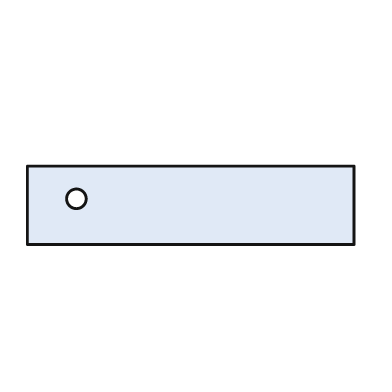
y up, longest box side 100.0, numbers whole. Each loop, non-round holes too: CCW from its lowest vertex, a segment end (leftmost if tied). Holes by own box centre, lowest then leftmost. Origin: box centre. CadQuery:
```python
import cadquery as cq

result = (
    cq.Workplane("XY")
    .moveTo(-50.0, -12.0)
    .lineTo(50.0, -12.0)
    .lineTo(50.0, 12.0)
    .lineTo(-50.0, 12.0)
    .close()
    .moveTo(-35.0, 2.0)
    .circle(3.0)
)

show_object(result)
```